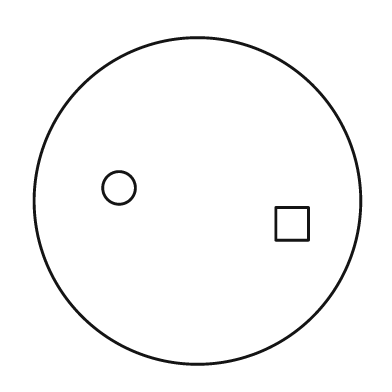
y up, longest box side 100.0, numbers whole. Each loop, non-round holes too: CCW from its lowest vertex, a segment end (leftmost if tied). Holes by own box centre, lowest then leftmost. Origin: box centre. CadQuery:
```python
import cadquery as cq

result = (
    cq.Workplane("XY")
    .moveTo(0.0, 0.0)
    .circle(50.0)
    .moveTo(24.0, -12.0)
    .lineTo(34.0, -12.0)
    .lineTo(34.0, -2.0)
    .lineTo(24.0, -2.0)
    .close()
    .moveTo(-24.0, 4.0)
    .circle(5.0)
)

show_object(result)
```